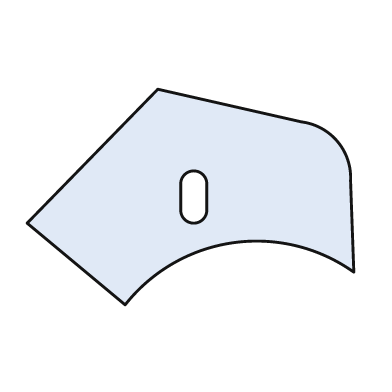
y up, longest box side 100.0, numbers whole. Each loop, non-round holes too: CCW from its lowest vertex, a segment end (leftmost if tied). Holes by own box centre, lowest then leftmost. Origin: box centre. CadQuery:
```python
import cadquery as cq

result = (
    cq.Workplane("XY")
    .moveTo(-20.0, -33.0)
    .threePointArc((13.0, -14.0), (50.0, -23.0))
    .lineTo(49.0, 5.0)
    .threePointArc((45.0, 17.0), (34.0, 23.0))
    .lineTo(-10.0, 33.0)
    .lineTo(-50.0, -8.0)
    .close()
    .moveTo(-3.0, -4.0)
    .threePointArc((1.0, -8.0), (5.0, -4.0))
    .lineTo(5.0, 4.0)
    .threePointArc((1.0, 8.0), (-3.0, 4.0))
    .close()
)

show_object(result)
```